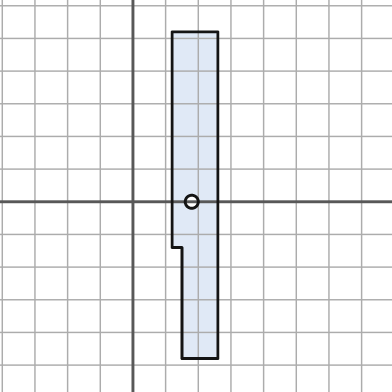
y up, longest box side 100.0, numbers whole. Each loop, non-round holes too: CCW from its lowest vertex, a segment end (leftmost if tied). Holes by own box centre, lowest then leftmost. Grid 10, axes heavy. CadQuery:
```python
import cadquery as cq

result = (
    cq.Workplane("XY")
    .moveTo(15.0, -48.0)
    .lineTo(26.0, -48.0)
    .lineTo(26.0, 52.0)
    .lineTo(12.0, 52.0)
    .lineTo(12.0, -14.0)
    .lineTo(15.0, -14.0)
    .close()
    .moveTo(18.0, 0.0)
    .circle(2.0)
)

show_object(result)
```